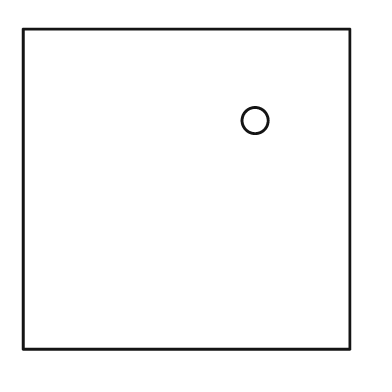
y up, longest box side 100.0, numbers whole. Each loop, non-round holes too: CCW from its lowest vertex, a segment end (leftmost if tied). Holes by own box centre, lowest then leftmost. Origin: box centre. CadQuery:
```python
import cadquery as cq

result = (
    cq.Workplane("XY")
    .moveTo(-50.0, -49.0)
    .lineTo(50.0, -49.0)
    .lineTo(50.0, 49.0)
    .lineTo(-50.0, 49.0)
    .close()
    .moveTo(21.0, 21.0)
    .circle(4.0)
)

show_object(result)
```